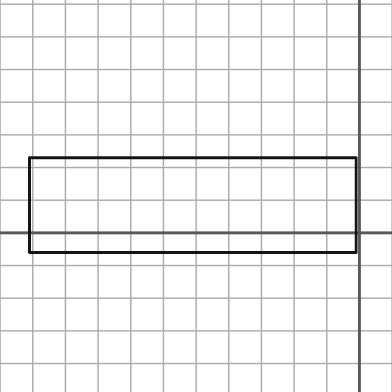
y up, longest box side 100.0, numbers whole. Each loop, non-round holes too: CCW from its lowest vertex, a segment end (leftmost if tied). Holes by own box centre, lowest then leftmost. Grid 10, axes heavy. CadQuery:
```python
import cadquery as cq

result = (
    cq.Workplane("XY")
    .moveTo(-101.0, -6.0)
    .lineTo(-1.0, -6.0)
    .lineTo(-1.0, 23.0)
    .lineTo(-101.0, 23.0)
    .close()
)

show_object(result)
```